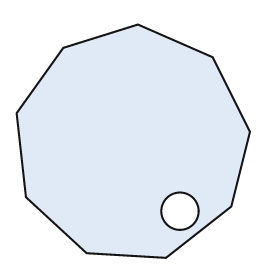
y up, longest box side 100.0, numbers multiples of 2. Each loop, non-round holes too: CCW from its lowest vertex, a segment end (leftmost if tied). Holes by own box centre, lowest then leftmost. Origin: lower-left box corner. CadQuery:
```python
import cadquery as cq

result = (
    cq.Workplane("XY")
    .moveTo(64.0, 0.0)
    .lineTo(92.0, 22.0)
    .lineTo(100.0, 54.0)
    .lineTo(84.0, 86.0)
    .lineTo(52.0, 100.0)
    .lineTo(20.0, 90.0)
    .lineTo(0.0, 62.0)
    .lineTo(4.0, 26.0)
    .lineTo(30.0, 2.0)
    .close()
    .moveTo(70.0, 20.0)
    .circle(8.0)
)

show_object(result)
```